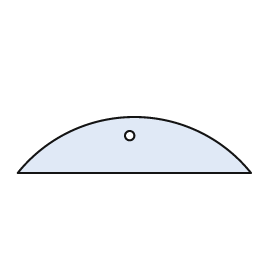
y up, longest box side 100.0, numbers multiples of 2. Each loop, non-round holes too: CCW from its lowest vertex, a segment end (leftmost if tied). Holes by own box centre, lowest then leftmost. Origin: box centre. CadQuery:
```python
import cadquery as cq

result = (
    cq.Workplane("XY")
    .moveTo(-50.0, -12.0)
    .lineTo(50.0, -12.0)
    .threePointArc((0.0, 12.0), (-50.0, -12.0))
    .close()
    .moveTo(-2.0, 4.0)
    .circle(2.0)
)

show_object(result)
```